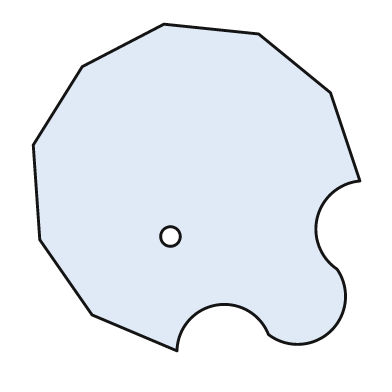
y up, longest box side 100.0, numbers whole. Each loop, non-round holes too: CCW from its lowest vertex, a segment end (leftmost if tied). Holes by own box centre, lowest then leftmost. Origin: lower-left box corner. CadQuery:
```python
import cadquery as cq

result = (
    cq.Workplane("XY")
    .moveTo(44.0, 0.0)
    .threePointArc((56.0, 14.0), (72.0, 5.0))
    .threePointArc((91.0, 6.0), (93.0, 25.0))
    .threePointArc((87.0, 41.0), (100.0, 52.0))
    .lineTo(91.0, 79.0)
    .lineTo(69.0, 97.0)
    .lineTo(40.0, 100.0)
    .lineTo(15.0, 87.0)
    .lineTo(0.0, 63.0)
    .lineTo(2.0, 34.0)
    .lineTo(18.0, 11.0)
    .close()
    .moveTo(42.0, 35.0)
    .circle(3.0)
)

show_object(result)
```